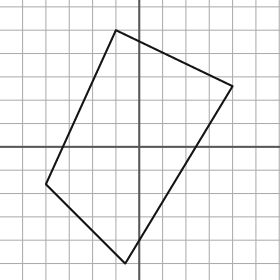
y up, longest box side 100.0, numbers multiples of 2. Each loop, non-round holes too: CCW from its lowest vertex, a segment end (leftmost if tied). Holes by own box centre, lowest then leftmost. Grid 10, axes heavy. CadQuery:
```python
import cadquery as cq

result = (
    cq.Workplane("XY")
    .moveTo(-6.0, -50.0)
    .lineTo(40.0, 26.0)
    .lineTo(-10.0, 50.0)
    .lineTo(-40.0, -16.0)
    .close()
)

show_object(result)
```